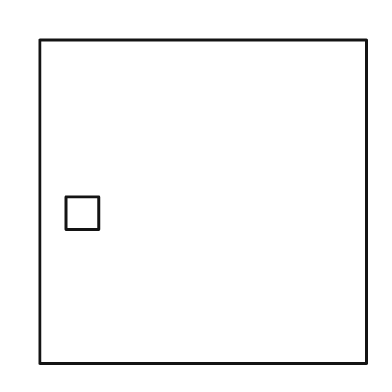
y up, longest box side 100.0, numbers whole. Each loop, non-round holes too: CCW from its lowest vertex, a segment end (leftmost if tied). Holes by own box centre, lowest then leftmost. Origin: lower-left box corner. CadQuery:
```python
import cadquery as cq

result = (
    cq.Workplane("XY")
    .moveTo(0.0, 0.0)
    .lineTo(100.0, 0.0)
    .lineTo(100.0, 99.0)
    .lineTo(0.0, 99.0)
    .close()
    .moveTo(8.0, 41.0)
    .lineTo(18.0, 41.0)
    .lineTo(18.0, 51.0)
    .lineTo(8.0, 51.0)
    .close()
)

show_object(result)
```